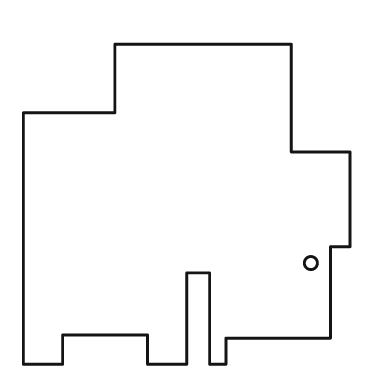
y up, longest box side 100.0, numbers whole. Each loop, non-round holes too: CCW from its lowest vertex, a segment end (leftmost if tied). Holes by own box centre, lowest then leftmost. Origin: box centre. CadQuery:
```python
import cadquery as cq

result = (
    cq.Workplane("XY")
    .moveTo(-50.0, -49.0)
    .lineTo(-38.0, -49.0)
    .lineTo(-38.0, -40.0)
    .lineTo(-12.0, -40.0)
    .lineTo(-12.0, -49.0)
    .lineTo(0.0, -49.0)
    .lineTo(0.0, -21.0)
    .lineTo(7.0, -21.0)
    .lineTo(7.0, -49.0)
    .lineTo(12.0, -49.0)
    .lineTo(12.0, -41.0)
    .lineTo(44.0, -41.0)
    .lineTo(44.0, -13.0)
    .lineTo(50.0, -13.0)
    .lineTo(50.0, 16.0)
    .lineTo(32.0, 16.0)
    .lineTo(32.0, 49.0)
    .lineTo(-22.0, 49.0)
    .lineTo(-22.0, 28.0)
    .lineTo(-50.0, 28.0)
    .close()
    .moveTo(38.0, -18.0)
    .circle(2.0)
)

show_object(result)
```